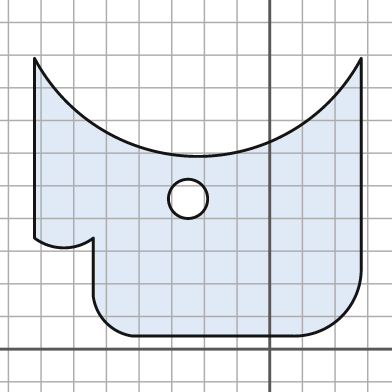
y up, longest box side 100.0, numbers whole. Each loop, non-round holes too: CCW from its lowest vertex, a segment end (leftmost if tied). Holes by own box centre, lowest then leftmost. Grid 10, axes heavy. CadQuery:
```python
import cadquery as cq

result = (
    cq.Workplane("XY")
    .moveTo(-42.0, 4.0)
    .lineTo(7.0, 4.0)
    .threePointArc((22.0, 10.0), (28.0, 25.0))
    .lineTo(28.0, 89.0)
    .threePointArc((-22.0, 59.0), (-72.0, 89.0))
    .lineTo(-72.0, 34.0)
    .threePointArc((-63.0, 31.0), (-54.0, 34.0))
    .lineTo(-54.0, 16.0)
    .threePointArc((-50.0, 8.0), (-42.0, 4.0))
    .close()
    .moveTo(-25.0, 46.0)
    .circle(6.0)
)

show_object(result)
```